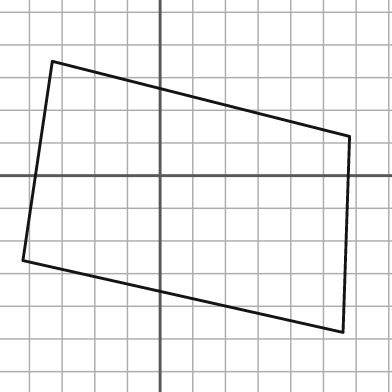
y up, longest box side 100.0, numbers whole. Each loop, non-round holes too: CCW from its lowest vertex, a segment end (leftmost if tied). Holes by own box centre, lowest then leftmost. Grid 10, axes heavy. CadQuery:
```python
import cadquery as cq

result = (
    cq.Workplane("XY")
    .moveTo(56.0, -48.0)
    .lineTo(58.0, 12.0)
    .lineTo(-33.0, 35.0)
    .lineTo(-42.0, -26.0)
    .close()
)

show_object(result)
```